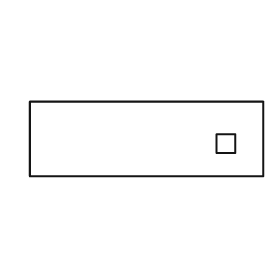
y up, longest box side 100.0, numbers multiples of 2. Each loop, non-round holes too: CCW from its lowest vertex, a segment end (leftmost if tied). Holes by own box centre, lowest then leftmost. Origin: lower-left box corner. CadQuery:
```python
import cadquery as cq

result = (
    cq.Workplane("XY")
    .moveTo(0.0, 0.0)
    .lineTo(100.0, 0.0)
    .lineTo(100.0, 32.0)
    .lineTo(0.0, 32.0)
    .close()
    .moveTo(80.0, 10.0)
    .lineTo(88.0, 10.0)
    .lineTo(88.0, 18.0)
    .lineTo(80.0, 18.0)
    .close()
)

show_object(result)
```